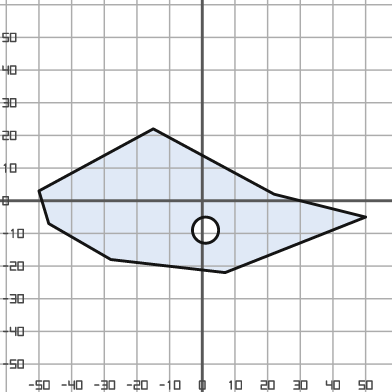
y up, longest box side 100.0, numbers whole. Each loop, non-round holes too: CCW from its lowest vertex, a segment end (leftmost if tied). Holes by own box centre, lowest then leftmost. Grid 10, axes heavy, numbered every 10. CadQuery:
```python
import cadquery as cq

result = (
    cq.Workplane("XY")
    .moveTo(7.0, -22.0)
    .lineTo(50.0, -5.0)
    .lineTo(22.0, 2.0)
    .lineTo(-15.0, 22.0)
    .lineTo(-50.0, 3.0)
    .lineTo(-47.0, -7.0)
    .lineTo(-28.0, -18.0)
    .close()
    .moveTo(1.0, -9.0)
    .circle(4.0)
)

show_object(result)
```